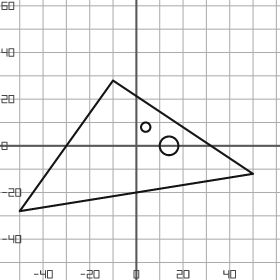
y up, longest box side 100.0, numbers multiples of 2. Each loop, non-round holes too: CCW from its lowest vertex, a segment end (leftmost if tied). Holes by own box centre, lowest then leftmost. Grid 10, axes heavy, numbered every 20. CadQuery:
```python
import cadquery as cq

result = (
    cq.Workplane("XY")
    .moveTo(-50.0, -28.0)
    .lineTo(50.0, -12.0)
    .lineTo(-10.0, 28.0)
    .close()
    .moveTo(14.0, 0.0)
    .circle(4.0)
    .moveTo(4.0, 8.0)
    .circle(2.0)
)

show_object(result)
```